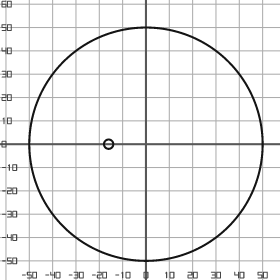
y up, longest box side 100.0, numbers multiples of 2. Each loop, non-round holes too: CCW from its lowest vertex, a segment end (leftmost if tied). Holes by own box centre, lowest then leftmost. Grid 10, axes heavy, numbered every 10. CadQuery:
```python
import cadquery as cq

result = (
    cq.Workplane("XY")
    .moveTo(0.0, 0.0)
    .circle(50.0)
    .moveTo(-16.0, 0.0)
    .circle(2.0)
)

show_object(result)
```